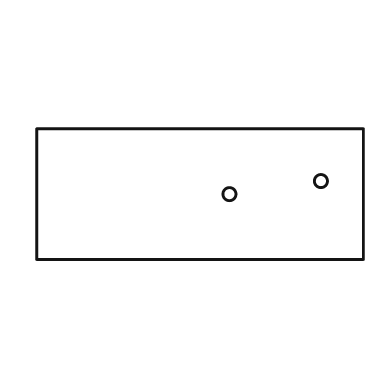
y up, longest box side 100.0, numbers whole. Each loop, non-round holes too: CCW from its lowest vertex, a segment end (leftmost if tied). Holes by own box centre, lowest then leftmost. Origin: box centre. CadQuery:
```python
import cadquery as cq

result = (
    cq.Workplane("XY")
    .moveTo(-50.0, -20.0)
    .lineTo(50.0, -20.0)
    .lineTo(50.0, 20.0)
    .lineTo(-50.0, 20.0)
    .close()
    .moveTo(9.0, 0.0)
    .circle(2.0)
    .moveTo(37.0, 4.0)
    .circle(2.0)
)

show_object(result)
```